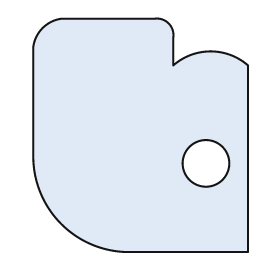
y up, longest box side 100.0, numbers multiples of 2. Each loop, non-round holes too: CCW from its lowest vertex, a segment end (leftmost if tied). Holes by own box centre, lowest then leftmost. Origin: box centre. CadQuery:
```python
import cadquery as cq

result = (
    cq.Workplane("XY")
    .moveTo(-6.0, -50.0)
    .lineTo(46.0, -50.0)
    .lineTo(46.0, 30.0)
    .threePointArc((30.0, 36.0), (14.0, 30.0))
    .lineTo(14.0, 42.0)
    .threePointArc((12.0, 48.0), (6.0, 50.0))
    .lineTo(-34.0, 50.0)
    .threePointArc((-42.0, 46.0), (-46.0, 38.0))
    .lineTo(-46.0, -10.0)
    .threePointArc((-34.0, -38.0), (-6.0, -50.0))
    .close()
    .moveTo(28.0, -12.0)
    .circle(10.0)
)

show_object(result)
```